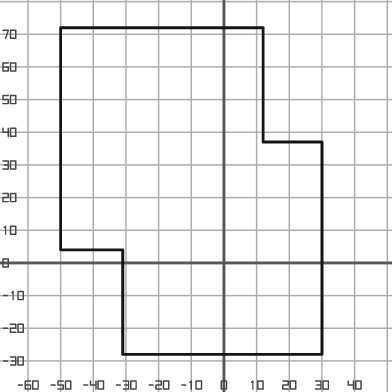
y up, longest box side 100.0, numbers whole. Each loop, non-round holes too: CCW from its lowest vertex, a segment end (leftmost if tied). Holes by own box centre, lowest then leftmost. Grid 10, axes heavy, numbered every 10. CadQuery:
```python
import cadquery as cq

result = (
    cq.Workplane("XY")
    .moveTo(-31.0, -28.0)
    .lineTo(30.0, -28.0)
    .lineTo(30.0, 37.0)
    .lineTo(12.0, 37.0)
    .lineTo(12.0, 72.0)
    .lineTo(-50.0, 72.0)
    .lineTo(-50.0, 4.0)
    .lineTo(-31.0, 4.0)
    .close()
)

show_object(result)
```